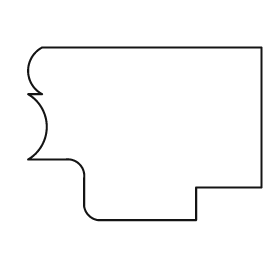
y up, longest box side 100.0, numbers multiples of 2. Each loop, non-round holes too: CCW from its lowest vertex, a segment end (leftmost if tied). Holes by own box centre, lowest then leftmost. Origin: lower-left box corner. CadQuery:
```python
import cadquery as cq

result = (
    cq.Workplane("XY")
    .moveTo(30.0, 0.0)
    .lineTo(72.0, 0.0)
    .lineTo(72.0, 14.0)
    .lineTo(100.0, 14.0)
    .lineTo(100.0, 74.0)
    .lineTo(6.0, 74.0)
    .threePointArc((0.0, 64.0), (6.0, 54.0))
    .lineTo(0.0, 54.0)
    .threePointArc((8.0, 40.0), (0.0, 26.0))
    .lineTo(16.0, 26.0)
    .threePointArc((22.0, 24.0), (24.0, 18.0))
    .lineTo(24.0, 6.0)
    .threePointArc((26.0, 2.0), (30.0, 0.0))
    .close()
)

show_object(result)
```